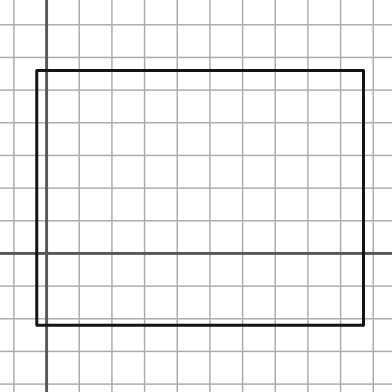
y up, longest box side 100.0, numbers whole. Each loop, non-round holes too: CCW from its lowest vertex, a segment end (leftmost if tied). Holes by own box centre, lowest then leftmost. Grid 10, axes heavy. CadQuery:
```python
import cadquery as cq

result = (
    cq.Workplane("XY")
    .moveTo(-3.0, -22.0)
    .lineTo(97.0, -22.0)
    .lineTo(97.0, 56.0)
    .lineTo(-3.0, 56.0)
    .close()
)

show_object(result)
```